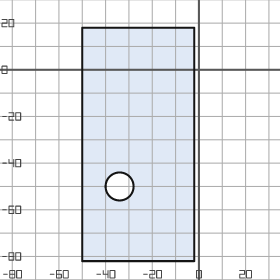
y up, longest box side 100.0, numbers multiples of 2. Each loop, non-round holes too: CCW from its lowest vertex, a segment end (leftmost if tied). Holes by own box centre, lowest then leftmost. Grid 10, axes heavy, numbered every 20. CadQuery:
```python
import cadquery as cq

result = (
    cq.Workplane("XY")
    .moveTo(-50.0, -82.0)
    .lineTo(-2.0, -82.0)
    .lineTo(-2.0, 18.0)
    .lineTo(-50.0, 18.0)
    .close()
    .moveTo(-34.0, -50.0)
    .circle(6.0)
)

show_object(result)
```